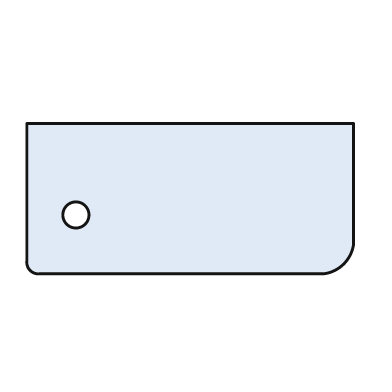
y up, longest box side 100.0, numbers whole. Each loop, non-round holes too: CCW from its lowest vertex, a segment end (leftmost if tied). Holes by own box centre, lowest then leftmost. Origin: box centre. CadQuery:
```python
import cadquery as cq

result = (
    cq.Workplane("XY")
    .moveTo(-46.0, -23.0)
    .lineTo(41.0, -23.0)
    .threePointArc((47.0, -20.0), (50.0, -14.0))
    .lineTo(50.0, 23.0)
    .lineTo(-50.0, 23.0)
    .lineTo(-50.0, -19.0)
    .threePointArc((-49.0, -22.0), (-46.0, -23.0))
    .close()
    .moveTo(-35.0, -5.0)
    .circle(4.0)
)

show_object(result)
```